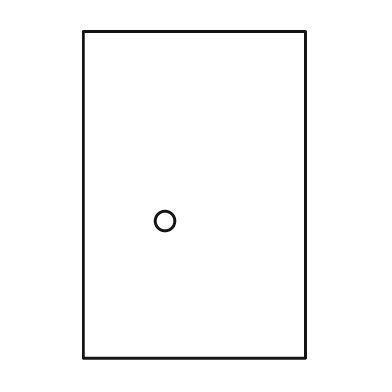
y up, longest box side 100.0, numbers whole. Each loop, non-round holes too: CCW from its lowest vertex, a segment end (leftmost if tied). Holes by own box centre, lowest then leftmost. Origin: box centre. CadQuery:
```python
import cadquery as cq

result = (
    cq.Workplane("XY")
    .moveTo(-34.0, -50.0)
    .lineTo(34.0, -50.0)
    .lineTo(34.0, 50.0)
    .lineTo(-34.0, 50.0)
    .close()
    .moveTo(-9.0, -8.0)
    .circle(3.0)
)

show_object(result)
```